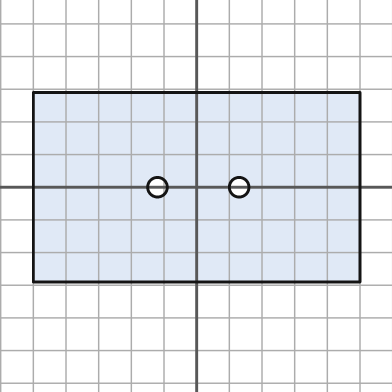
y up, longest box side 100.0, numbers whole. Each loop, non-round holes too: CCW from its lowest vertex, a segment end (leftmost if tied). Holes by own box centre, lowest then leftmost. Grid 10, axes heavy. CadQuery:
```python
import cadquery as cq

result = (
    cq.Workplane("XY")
    .moveTo(-50.0, -29.0)
    .lineTo(50.0, -29.0)
    .lineTo(50.0, 29.0)
    .lineTo(-50.0, 29.0)
    .close()
    .moveTo(-12.0, 0.0)
    .circle(3.0)
    .moveTo(13.0, 0.0)
    .circle(3.0)
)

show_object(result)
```